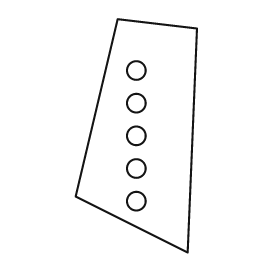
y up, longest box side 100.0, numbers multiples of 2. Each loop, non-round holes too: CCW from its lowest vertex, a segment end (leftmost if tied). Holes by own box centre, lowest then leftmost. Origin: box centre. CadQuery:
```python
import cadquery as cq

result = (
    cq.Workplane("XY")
    .moveTo(22.0, -50.0)
    .lineTo(26.0, 46.0)
    .lineTo(-8.0, 50.0)
    .lineTo(-26.0, -26.0)
    .close()
    .moveTo(0.0, -28.0)
    .circle(4.0)
    .moveTo(0.0, -14.0)
    .circle(4.0)
    .moveTo(0.0, 0.0)
    .circle(4.0)
    .moveTo(0.0, 14.0)
    .circle(4.0)
    .moveTo(0.0, 28.0)
    .circle(4.0)
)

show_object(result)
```